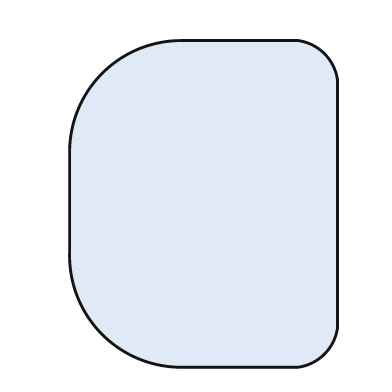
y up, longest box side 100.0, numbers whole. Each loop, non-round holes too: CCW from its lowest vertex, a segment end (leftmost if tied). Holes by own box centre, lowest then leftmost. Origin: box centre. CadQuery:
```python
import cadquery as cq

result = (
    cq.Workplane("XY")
    .moveTo(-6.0, -50.0)
    .lineTo(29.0, -50.0)
    .threePointArc((37.0, -46.0), (41.0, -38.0))
    .lineTo(41.0, 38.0)
    .threePointArc((37.0, 46.0), (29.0, 50.0))
    .lineTo(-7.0, 50.0)
    .threePointArc((-31.0, 40.0), (-41.0, 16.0))
    .lineTo(-41.0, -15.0)
    .threePointArc((-31.0, -40.0), (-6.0, -50.0))
    .close()
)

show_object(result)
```